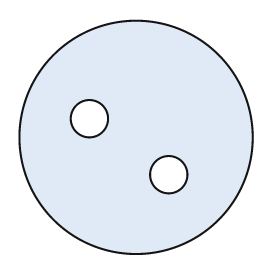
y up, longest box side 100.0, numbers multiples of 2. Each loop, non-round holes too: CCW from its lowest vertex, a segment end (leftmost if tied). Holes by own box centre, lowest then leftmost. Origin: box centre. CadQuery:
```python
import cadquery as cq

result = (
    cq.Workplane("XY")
    .moveTo(0.0, 0.0)
    .circle(50.0)
    .moveTo(14.0, -16.0)
    .circle(8.0)
    .moveTo(-20.0, 8.0)
    .circle(8.0)
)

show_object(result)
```